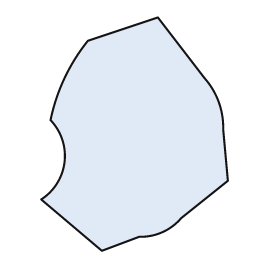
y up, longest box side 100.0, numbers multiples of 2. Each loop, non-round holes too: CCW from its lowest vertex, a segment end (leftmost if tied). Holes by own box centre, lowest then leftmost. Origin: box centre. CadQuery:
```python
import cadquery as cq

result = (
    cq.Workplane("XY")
    .moveTo(-14.0, -50.0)
    .lineTo(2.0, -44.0)
    .threePointArc((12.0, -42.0), (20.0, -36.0))
    .lineTo(40.0, -20.0)
    .lineTo(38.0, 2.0)
    .threePointArc((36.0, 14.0), (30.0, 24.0))
    .lineTo(10.0, 50.0)
    .lineTo(-20.0, 40.0)
    .threePointArc((-30.0, 24.0), (-36.0, 6.0))
    .threePointArc((-30.0, -12.0), (-40.0, -28.0))
    .close()
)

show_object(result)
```